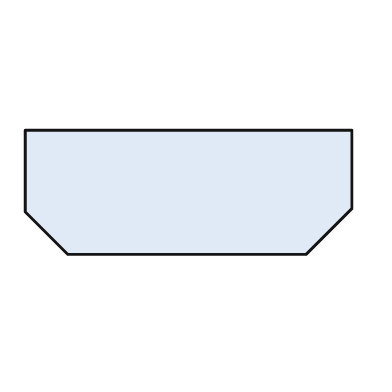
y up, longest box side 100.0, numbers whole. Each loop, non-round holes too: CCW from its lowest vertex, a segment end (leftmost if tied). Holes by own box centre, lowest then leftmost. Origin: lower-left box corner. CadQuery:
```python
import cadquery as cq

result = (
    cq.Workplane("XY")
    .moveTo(13.0, 0.0)
    .lineTo(86.0, 0.0)
    .lineTo(100.0, 14.0)
    .lineTo(100.0, 38.0)
    .lineTo(0.0, 38.0)
    .lineTo(0.0, 13.0)
    .close()
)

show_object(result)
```